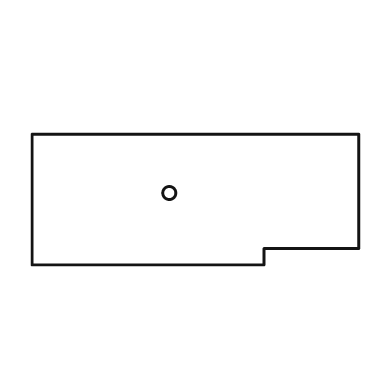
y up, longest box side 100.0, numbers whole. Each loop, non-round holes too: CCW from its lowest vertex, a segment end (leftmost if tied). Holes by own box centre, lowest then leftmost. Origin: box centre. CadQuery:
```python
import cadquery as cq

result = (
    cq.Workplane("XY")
    .moveTo(-50.0, -20.0)
    .lineTo(21.0, -20.0)
    .lineTo(21.0, -15.0)
    .lineTo(50.0, -15.0)
    .lineTo(50.0, 20.0)
    .lineTo(-50.0, 20.0)
    .close()
    .moveTo(-8.0, 2.0)
    .circle(2.0)
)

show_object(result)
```